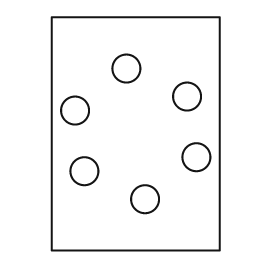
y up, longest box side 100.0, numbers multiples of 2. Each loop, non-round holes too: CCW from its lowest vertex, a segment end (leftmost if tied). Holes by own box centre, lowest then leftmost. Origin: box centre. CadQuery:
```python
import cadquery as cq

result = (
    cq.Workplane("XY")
    .moveTo(-36.0, -50.0)
    .lineTo(36.0, -50.0)
    .lineTo(36.0, 50.0)
    .lineTo(-36.0, 50.0)
    .close()
    .moveTo(4.0, -28.0)
    .circle(6.0)
    .moveTo(-22.0, -16.0)
    .circle(6.0)
    .moveTo(26.0, -10.0)
    .circle(6.0)
    .moveTo(-26.0, 10.0)
    .circle(6.0)
    .moveTo(22.0, 16.0)
    .circle(6.0)
    .moveTo(-4.0, 28.0)
    .circle(6.0)
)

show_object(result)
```